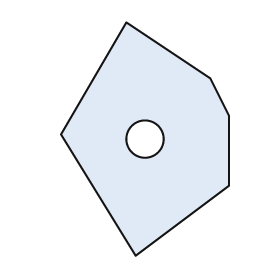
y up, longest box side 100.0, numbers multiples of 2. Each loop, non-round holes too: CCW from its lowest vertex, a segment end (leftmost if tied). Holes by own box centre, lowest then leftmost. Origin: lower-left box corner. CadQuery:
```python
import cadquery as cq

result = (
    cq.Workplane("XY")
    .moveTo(32.0, 0.0)
    .lineTo(72.0, 30.0)
    .lineTo(72.0, 60.0)
    .lineTo(64.0, 76.0)
    .lineTo(28.0, 100.0)
    .lineTo(0.0, 52.0)
    .close()
    .moveTo(36.0, 50.0)
    .circle(8.0)
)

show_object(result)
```